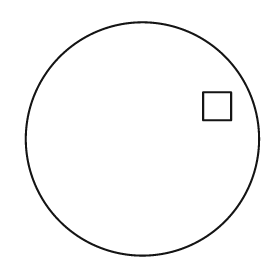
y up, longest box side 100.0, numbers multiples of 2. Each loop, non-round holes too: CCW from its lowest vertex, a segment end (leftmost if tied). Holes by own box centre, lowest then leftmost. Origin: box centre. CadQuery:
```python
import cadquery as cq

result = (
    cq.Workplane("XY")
    .moveTo(0.0, 0.0)
    .circle(50.0)
    .moveTo(26.0, 8.0)
    .lineTo(38.0, 8.0)
    .lineTo(38.0, 20.0)
    .lineTo(26.0, 20.0)
    .close()
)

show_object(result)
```